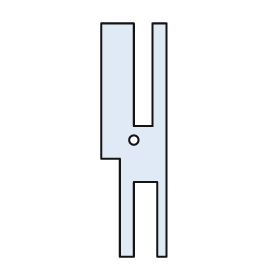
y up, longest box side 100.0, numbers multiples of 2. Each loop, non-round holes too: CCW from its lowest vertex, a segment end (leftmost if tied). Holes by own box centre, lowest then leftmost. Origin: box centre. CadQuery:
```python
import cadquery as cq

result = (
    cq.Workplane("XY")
    .moveTo(-6.0, -50.0)
    .lineTo(0.0, -50.0)
    .lineTo(0.0, -18.0)
    .lineTo(10.0, -18.0)
    .lineTo(10.0, -50.0)
    .lineTo(14.0, -50.0)
    .lineTo(14.0, 50.0)
    .lineTo(8.0, 50.0)
    .lineTo(8.0, 6.0)
    .lineTo(0.0, 6.0)
    .lineTo(0.0, 50.0)
    .lineTo(-14.0, 50.0)
    .lineTo(-14.0, -8.0)
    .lineTo(-6.0, -8.0)
    .close()
    .moveTo(0.0, 0.0)
    .circle(2.0)
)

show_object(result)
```